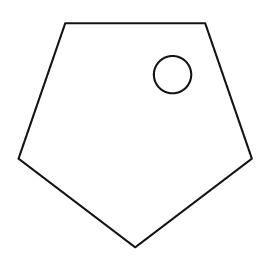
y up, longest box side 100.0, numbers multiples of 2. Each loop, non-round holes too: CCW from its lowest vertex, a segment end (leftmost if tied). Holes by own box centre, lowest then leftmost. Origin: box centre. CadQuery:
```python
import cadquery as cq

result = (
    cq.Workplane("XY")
    .moveTo(0.0, -48.0)
    .lineTo(50.0, -10.0)
    .lineTo(30.0, 48.0)
    .lineTo(-30.0, 48.0)
    .lineTo(-50.0, -10.0)
    .close()
    .moveTo(16.0, 26.0)
    .circle(8.0)
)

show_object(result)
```